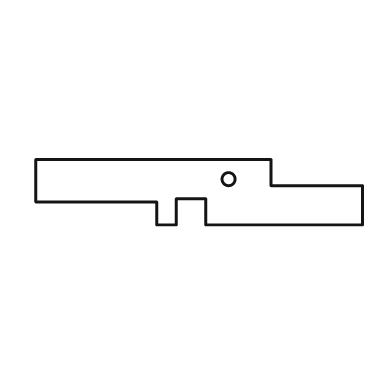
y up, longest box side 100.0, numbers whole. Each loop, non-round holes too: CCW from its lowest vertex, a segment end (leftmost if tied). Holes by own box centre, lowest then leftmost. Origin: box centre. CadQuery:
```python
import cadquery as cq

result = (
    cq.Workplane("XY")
    .moveTo(-13.0, -10.0)
    .lineTo(-7.0, -10.0)
    .lineTo(-7.0, -2.0)
    .lineTo(2.0, -2.0)
    .lineTo(2.0, -10.0)
    .lineTo(50.0, -10.0)
    .lineTo(50.0, 2.0)
    .lineTo(22.0, 2.0)
    .lineTo(22.0, 10.0)
    .lineTo(-50.0, 10.0)
    .lineTo(-50.0, -3.0)
    .lineTo(-13.0, -3.0)
    .close()
    .moveTo(9.0, 4.0)
    .circle(2.0)
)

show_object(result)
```